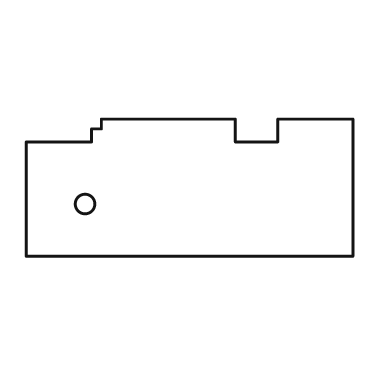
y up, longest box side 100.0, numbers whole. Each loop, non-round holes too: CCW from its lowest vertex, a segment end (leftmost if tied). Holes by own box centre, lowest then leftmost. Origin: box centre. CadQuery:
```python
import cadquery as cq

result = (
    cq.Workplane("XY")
    .moveTo(-50.0, -21.0)
    .lineTo(50.0, -21.0)
    .lineTo(50.0, 21.0)
    .lineTo(27.0, 21.0)
    .lineTo(27.0, 14.0)
    .lineTo(14.0, 14.0)
    .lineTo(14.0, 21.0)
    .lineTo(-27.0, 21.0)
    .lineTo(-27.0, 18.0)
    .lineTo(-30.0, 18.0)
    .lineTo(-30.0, 14.0)
    .lineTo(-50.0, 14.0)
    .close()
    .moveTo(-32.0, -5.0)
    .circle(3.0)
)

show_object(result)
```